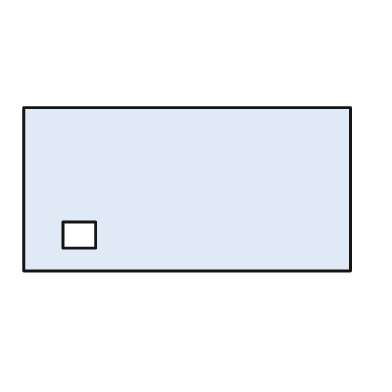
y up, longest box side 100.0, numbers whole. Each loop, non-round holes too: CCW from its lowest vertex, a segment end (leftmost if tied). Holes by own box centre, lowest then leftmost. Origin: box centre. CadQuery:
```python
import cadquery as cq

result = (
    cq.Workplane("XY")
    .moveTo(-50.0, -25.0)
    .lineTo(50.0, -25.0)
    .lineTo(50.0, 25.0)
    .lineTo(-50.0, 25.0)
    .close()
    .moveTo(-38.0, -18.0)
    .lineTo(-28.0, -18.0)
    .lineTo(-28.0, -10.0)
    .lineTo(-38.0, -10.0)
    .close()
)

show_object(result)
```